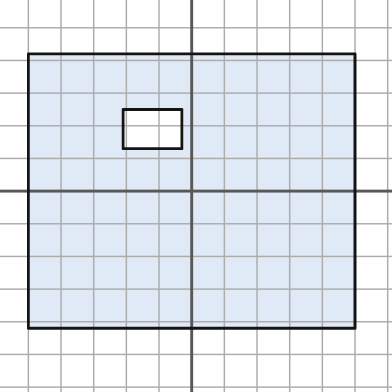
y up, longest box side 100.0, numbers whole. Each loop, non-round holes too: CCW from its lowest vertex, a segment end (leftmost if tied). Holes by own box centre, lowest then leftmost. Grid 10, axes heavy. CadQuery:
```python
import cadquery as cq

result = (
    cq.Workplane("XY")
    .moveTo(-50.0, -42.0)
    .lineTo(50.0, -42.0)
    .lineTo(50.0, 42.0)
    .lineTo(-50.0, 42.0)
    .close()
    .moveTo(-21.0, 13.0)
    .lineTo(-3.0, 13.0)
    .lineTo(-3.0, 25.0)
    .lineTo(-21.0, 25.0)
    .close()
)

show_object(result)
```